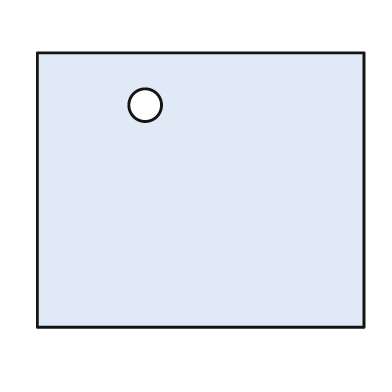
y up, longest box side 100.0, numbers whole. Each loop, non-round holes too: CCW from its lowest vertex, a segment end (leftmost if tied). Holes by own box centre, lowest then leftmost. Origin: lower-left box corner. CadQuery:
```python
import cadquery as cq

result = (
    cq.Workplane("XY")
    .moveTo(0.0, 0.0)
    .lineTo(100.0, 0.0)
    .lineTo(100.0, 84.0)
    .lineTo(0.0, 84.0)
    .close()
    .moveTo(33.0, 68.0)
    .circle(5.0)
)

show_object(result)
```